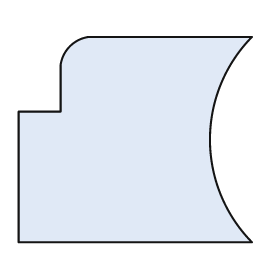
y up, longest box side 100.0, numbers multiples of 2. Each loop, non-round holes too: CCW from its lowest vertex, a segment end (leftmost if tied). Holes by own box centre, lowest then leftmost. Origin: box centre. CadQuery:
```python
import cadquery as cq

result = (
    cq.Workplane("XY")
    .moveTo(-50.0, -44.0)
    .lineTo(50.0, -44.0)
    .threePointArc((32.0, 0.0), (50.0, 44.0))
    .lineTo(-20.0, 44.0)
    .threePointArc((-28.0, 40.0), (-32.0, 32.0))
    .lineTo(-32.0, 12.0)
    .lineTo(-50.0, 12.0)
    .close()
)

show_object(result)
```